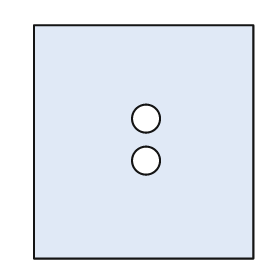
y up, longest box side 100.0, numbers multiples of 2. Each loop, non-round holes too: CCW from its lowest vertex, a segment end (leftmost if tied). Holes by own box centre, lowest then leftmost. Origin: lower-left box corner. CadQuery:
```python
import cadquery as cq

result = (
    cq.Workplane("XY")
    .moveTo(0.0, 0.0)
    .lineTo(94.0, 0.0)
    .lineTo(94.0, 100.0)
    .lineTo(0.0, 100.0)
    .close()
    .moveTo(48.0, 42.0)
    .circle(6.0)
    .moveTo(48.0, 60.0)
    .circle(6.0)
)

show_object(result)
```